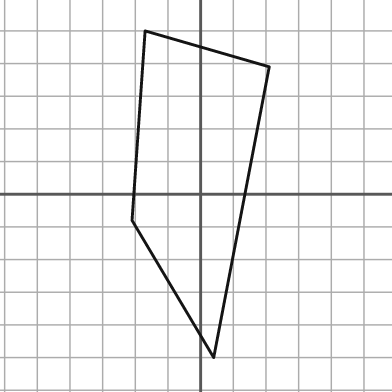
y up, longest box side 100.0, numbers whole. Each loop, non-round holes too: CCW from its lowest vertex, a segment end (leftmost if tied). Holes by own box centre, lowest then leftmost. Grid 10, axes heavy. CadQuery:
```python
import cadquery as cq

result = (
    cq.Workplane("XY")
    .moveTo(4.0, -50.0)
    .lineTo(21.0, 39.0)
    .lineTo(-17.0, 50.0)
    .lineTo(-21.0, -8.0)
    .close()
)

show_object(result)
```